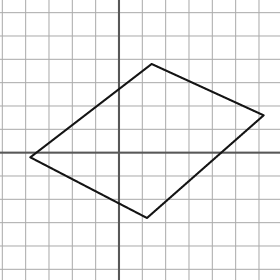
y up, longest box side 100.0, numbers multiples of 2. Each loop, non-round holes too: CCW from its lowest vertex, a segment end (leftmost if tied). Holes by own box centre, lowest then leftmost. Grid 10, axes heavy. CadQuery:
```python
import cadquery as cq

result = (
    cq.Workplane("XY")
    .moveTo(12.0, -28.0)
    .lineTo(62.0, 16.0)
    .lineTo(14.0, 38.0)
    .lineTo(-38.0, -2.0)
    .close()
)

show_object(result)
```